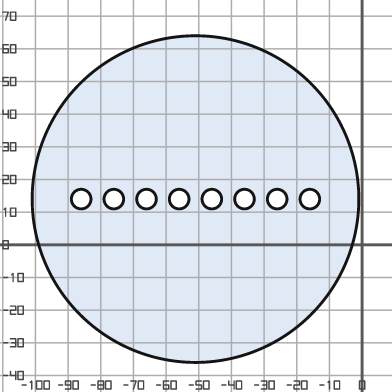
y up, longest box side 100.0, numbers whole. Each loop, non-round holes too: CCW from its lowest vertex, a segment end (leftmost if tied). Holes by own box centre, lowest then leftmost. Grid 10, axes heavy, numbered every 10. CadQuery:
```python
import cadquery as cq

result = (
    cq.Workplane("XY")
    .moveTo(-51.0, 14.0)
    .circle(50.0)
    .moveTo(-86.0, 14.0)
    .circle(3.0)
    .moveTo(-76.0, 14.0)
    .circle(3.0)
    .moveTo(-66.0, 14.0)
    .circle(3.0)
    .moveTo(-56.0, 14.0)
    .circle(3.0)
    .moveTo(-46.0, 14.0)
    .circle(3.0)
    .moveTo(-36.0, 14.0)
    .circle(3.0)
    .moveTo(-26.0, 14.0)
    .circle(3.0)
    .moveTo(-16.0, 14.0)
    .circle(3.0)
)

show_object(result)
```